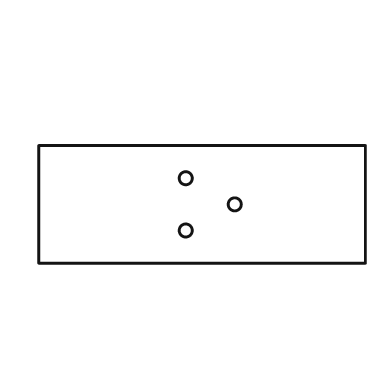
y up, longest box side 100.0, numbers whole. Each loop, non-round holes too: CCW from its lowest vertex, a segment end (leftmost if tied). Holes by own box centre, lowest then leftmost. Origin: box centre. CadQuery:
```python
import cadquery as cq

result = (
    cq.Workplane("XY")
    .moveTo(-50.0, -18.0)
    .lineTo(50.0, -18.0)
    .lineTo(50.0, 18.0)
    .lineTo(-50.0, 18.0)
    .close()
    .moveTo(-5.0, -8.0)
    .circle(2.0)
    .moveTo(10.0, 0.0)
    .circle(2.0)
    .moveTo(-5.0, 8.0)
    .circle(2.0)
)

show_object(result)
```